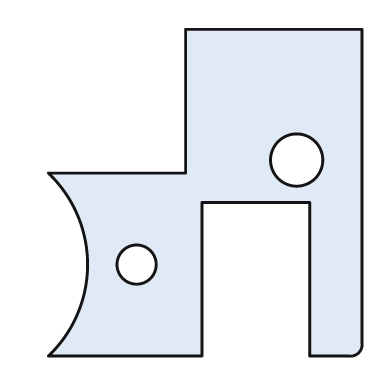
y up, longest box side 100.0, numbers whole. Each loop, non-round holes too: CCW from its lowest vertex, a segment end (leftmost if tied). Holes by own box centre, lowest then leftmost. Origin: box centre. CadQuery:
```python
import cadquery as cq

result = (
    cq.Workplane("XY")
    .moveTo(-48.0, -50.0)
    .lineTo(-1.0, -50.0)
    .lineTo(-1.0, -3.0)
    .lineTo(32.0, -3.0)
    .lineTo(32.0, -50.0)
    .lineTo(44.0, -50.0)
    .threePointArc((47.0, -49.0), (48.0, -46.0))
    .lineTo(48.0, 50.0)
    .lineTo(-6.0, 50.0)
    .lineTo(-6.0, 6.0)
    .lineTo(-48.0, 6.0)
    .threePointArc((-36.0, -22.0), (-48.0, -50.0))
    .close()
    .moveTo(-21.0, -22.0)
    .circle(6.0)
    .moveTo(28.0, 10.0)
    .circle(8.0)
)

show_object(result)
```